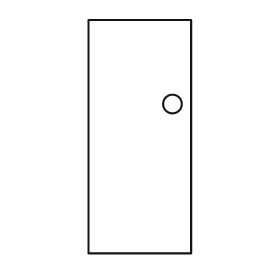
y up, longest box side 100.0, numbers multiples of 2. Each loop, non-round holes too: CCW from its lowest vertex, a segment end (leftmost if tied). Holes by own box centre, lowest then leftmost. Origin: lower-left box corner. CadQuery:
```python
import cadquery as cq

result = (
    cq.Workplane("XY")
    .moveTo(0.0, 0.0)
    .lineTo(44.0, 0.0)
    .lineTo(44.0, 100.0)
    .lineTo(0.0, 100.0)
    .close()
    .moveTo(36.0, 64.0)
    .circle(4.0)
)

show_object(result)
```